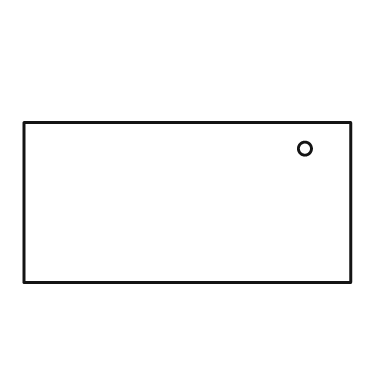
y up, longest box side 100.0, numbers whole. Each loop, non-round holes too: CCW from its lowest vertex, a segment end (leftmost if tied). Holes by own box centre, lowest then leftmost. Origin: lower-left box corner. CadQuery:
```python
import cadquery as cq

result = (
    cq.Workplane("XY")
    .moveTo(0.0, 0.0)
    .lineTo(100.0, 0.0)
    .lineTo(100.0, 49.0)
    .lineTo(0.0, 49.0)
    .close()
    .moveTo(86.0, 41.0)
    .circle(2.0)
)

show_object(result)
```